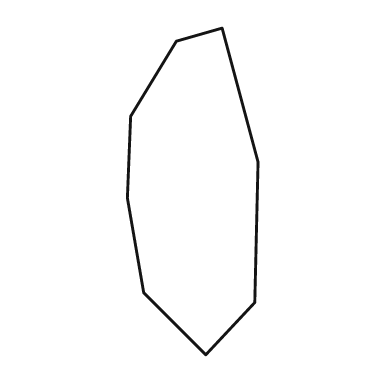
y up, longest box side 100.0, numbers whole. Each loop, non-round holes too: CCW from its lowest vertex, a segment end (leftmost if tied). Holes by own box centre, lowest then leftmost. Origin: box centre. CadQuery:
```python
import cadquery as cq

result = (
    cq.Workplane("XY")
    .moveTo(4.0, -50.0)
    .lineTo(19.0, -34.0)
    .lineTo(20.0, 9.0)
    .lineTo(9.0, 50.0)
    .lineTo(-5.0, 46.0)
    .lineTo(-19.0, 23.0)
    .lineTo(-20.0, -2.0)
    .lineTo(-15.0, -31.0)
    .close()
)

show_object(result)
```